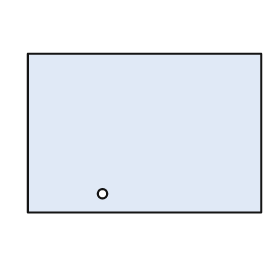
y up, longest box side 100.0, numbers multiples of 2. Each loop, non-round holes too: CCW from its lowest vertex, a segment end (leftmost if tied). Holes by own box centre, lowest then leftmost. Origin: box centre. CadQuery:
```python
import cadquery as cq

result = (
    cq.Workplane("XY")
    .moveTo(-50.0, -34.0)
    .lineTo(50.0, -34.0)
    .lineTo(50.0, 34.0)
    .lineTo(-50.0, 34.0)
    .close()
    .moveTo(-18.0, -26.0)
    .circle(2.0)
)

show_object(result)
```